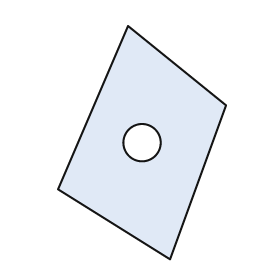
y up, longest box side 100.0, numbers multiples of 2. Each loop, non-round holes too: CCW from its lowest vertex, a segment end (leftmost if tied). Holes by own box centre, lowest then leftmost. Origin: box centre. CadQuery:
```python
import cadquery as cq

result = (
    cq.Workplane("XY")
    .moveTo(12.0, -50.0)
    .lineTo(36.0, 16.0)
    .lineTo(-6.0, 50.0)
    .lineTo(-36.0, -20.0)
    .close()
    .moveTo(0.0, 0.0)
    .circle(8.0)
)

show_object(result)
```